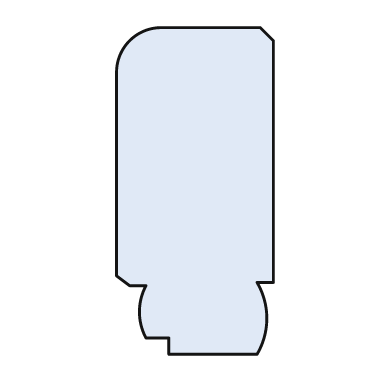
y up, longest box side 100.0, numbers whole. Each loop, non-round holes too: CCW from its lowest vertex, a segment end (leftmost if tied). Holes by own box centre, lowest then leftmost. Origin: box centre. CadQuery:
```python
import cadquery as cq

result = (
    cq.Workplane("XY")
    .moveTo(-8.0, -50.0)
    .lineTo(19.0, -50.0)
    .threePointArc((22.0, -39.0), (19.0, -28.0))
    .lineTo(24.0, -28.0)
    .lineTo(24.0, 46.0)
    .lineTo(20.0, 50.0)
    .lineTo(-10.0, 50.0)
    .threePointArc((-20.0, 46.0), (-24.0, 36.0))
    .lineTo(-24.0, -26.0)
    .lineTo(-20.0, -29.0)
    .lineTo(-15.0, -29.0)
    .threePointArc((-17.0, -37.0), (-15.0, -45.0))
    .lineTo(-8.0, -45.0)
    .close()
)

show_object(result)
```